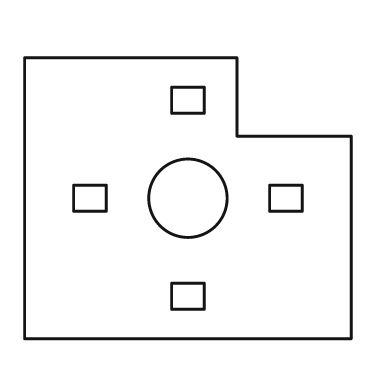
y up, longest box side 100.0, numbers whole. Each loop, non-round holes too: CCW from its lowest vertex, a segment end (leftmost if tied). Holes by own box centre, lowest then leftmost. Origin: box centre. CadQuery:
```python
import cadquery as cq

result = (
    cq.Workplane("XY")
    .moveTo(-50.0, -43.0)
    .lineTo(50.0, -43.0)
    .lineTo(50.0, 19.0)
    .lineTo(15.0, 19.0)
    .lineTo(15.0, 43.0)
    .lineTo(-50.0, 43.0)
    .close()
    .moveTo(-5.0, -34.0)
    .lineTo(5.0, -34.0)
    .lineTo(5.0, -26.0)
    .lineTo(-5.0, -26.0)
    .close()
    .moveTo(-35.0, -4.0)
    .lineTo(-25.0, -4.0)
    .lineTo(-25.0, 4.0)
    .lineTo(-35.0, 4.0)
    .close()
    .moveTo(0.0, 0.0)
    .circle(12.0)
    .moveTo(25.0, -4.0)
    .lineTo(35.0, -4.0)
    .lineTo(35.0, 4.0)
    .lineTo(25.0, 4.0)
    .close()
    .moveTo(-5.0, 26.0)
    .lineTo(5.0, 26.0)
    .lineTo(5.0, 34.0)
    .lineTo(-5.0, 34.0)
    .close()
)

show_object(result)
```